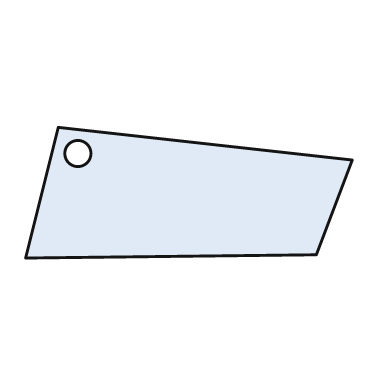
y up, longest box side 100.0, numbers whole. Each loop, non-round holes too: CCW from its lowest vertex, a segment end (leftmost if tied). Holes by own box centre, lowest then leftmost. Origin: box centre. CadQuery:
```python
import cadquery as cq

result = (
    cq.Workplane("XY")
    .moveTo(-50.0, -20.0)
    .lineTo(39.0, -19.0)
    .lineTo(50.0, 10.0)
    .lineTo(-40.0, 20.0)
    .close()
    .moveTo(-34.0, 12.0)
    .circle(4.0)
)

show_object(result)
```